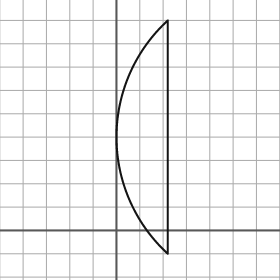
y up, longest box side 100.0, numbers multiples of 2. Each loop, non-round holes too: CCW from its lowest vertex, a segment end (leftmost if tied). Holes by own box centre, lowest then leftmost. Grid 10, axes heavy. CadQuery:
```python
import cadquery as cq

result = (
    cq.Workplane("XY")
    .moveTo(22.0, -10.0)
    .lineTo(22.0, 90.0)
    .threePointArc((0.0, 40.0), (22.0, -10.0))
    .close()
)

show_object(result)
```